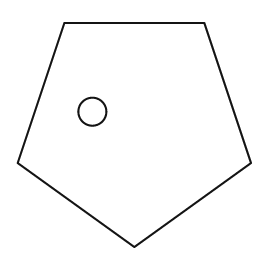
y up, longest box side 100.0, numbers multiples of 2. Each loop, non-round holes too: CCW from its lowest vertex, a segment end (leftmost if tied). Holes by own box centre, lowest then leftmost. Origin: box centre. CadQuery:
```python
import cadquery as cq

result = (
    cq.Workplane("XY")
    .moveTo(0.0, -48.0)
    .lineTo(50.0, -12.0)
    .lineTo(30.0, 48.0)
    .lineTo(-30.0, 48.0)
    .lineTo(-50.0, -12.0)
    .close()
    .moveTo(-18.0, 10.0)
    .circle(6.0)
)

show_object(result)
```